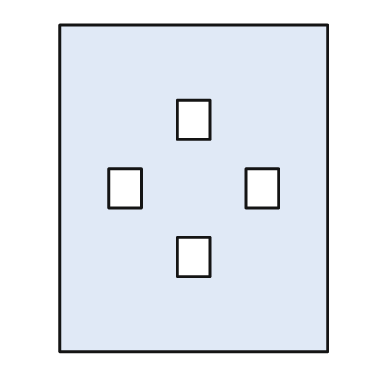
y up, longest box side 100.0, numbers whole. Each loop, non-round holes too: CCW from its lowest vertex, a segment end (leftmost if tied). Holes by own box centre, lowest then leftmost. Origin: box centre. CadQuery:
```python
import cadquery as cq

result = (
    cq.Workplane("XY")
    .moveTo(-41.0, -50.0)
    .lineTo(41.0, -50.0)
    .lineTo(41.0, 50.0)
    .lineTo(-41.0, 50.0)
    .close()
    .moveTo(-5.0, -27.0)
    .lineTo(5.0, -27.0)
    .lineTo(5.0, -15.0)
    .lineTo(-5.0, -15.0)
    .close()
    .moveTo(-26.0, -6.0)
    .lineTo(-16.0, -6.0)
    .lineTo(-16.0, 6.0)
    .lineTo(-26.0, 6.0)
    .close()
    .moveTo(16.0, -6.0)
    .lineTo(26.0, -6.0)
    .lineTo(26.0, 6.0)
    .lineTo(16.0, 6.0)
    .close()
    .moveTo(-5.0, 15.0)
    .lineTo(5.0, 15.0)
    .lineTo(5.0, 27.0)
    .lineTo(-5.0, 27.0)
    .close()
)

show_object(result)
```